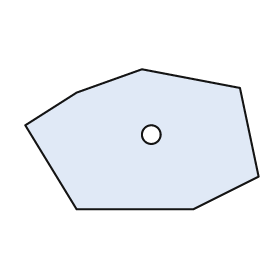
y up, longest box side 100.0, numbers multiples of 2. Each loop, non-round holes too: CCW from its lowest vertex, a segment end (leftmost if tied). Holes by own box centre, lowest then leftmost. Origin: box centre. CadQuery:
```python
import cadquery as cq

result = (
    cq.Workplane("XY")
    .moveTo(-28.0, -30.0)
    .lineTo(22.0, -30.0)
    .lineTo(50.0, -16.0)
    .lineTo(42.0, 22.0)
    .lineTo(0.0, 30.0)
    .lineTo(-28.0, 20.0)
    .lineTo(-50.0, 6.0)
    .close()
    .moveTo(4.0, 2.0)
    .circle(4.0)
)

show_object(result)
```